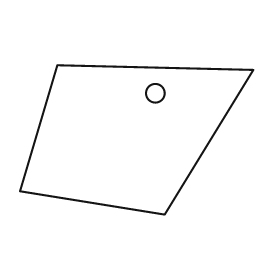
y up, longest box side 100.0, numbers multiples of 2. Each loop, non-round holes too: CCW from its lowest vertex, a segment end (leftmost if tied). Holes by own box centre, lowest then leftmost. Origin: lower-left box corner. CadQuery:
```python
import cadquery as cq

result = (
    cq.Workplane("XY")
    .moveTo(62.0, 0.0)
    .lineTo(100.0, 62.0)
    .lineTo(16.0, 64.0)
    .lineTo(0.0, 10.0)
    .close()
    .moveTo(58.0, 52.0)
    .circle(4.0)
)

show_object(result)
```